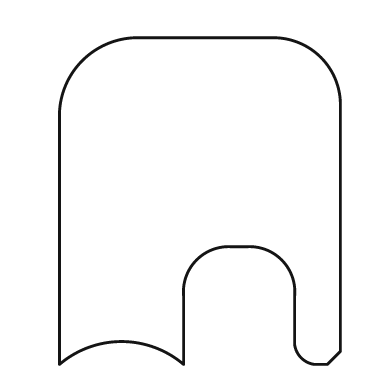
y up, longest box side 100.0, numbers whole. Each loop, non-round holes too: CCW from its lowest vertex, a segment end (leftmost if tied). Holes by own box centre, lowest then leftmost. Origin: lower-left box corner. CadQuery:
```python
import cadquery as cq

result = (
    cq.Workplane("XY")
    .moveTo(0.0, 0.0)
    .threePointArc((19.0, 7.0), (38.0, 0.0))
    .lineTo(38.0, 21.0)
    .threePointArc((42.0, 32.0), (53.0, 36.0))
    .lineTo(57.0, 36.0)
    .threePointArc((68.0, 32.0), (72.0, 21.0))
    .lineTo(72.0, 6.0)
    .threePointArc((74.0, 2.0), (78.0, 0.0))
    .lineTo(82.0, 0.0)
    .lineTo(86.0, 4.0)
    .lineTo(86.0, 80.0)
    .threePointArc((80.0, 94.0), (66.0, 100.0))
    .lineTo(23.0, 100.0)
    .threePointArc((7.0, 93.0), (0.0, 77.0))
    .close()
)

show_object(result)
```